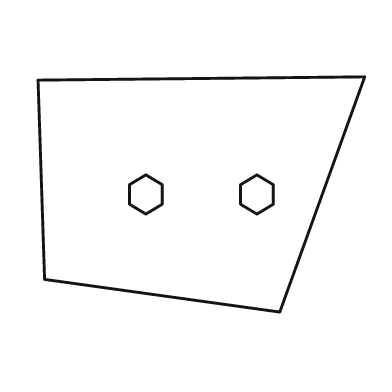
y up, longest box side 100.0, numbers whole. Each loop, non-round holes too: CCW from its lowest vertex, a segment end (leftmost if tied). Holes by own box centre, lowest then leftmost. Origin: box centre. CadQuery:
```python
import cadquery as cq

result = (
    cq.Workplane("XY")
    .moveTo(24.0, -36.0)
    .lineTo(50.0, 36.0)
    .lineTo(-50.0, 35.0)
    .lineTo(-48.0, -26.0)
    .close()
    .moveTo(-17.0, -6.0)
    .lineTo(-12.0, -3.0)
    .lineTo(-12.0, 3.0)
    .lineTo(-17.0, 6.0)
    .lineTo(-22.0, 3.0)
    .lineTo(-22.0, -3.0)
    .close()
    .moveTo(17.0, -6.0)
    .lineTo(22.0, -3.0)
    .lineTo(22.0, 3.0)
    .lineTo(17.0, 6.0)
    .lineTo(12.0, 3.0)
    .lineTo(12.0, -3.0)
    .close()
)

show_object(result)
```